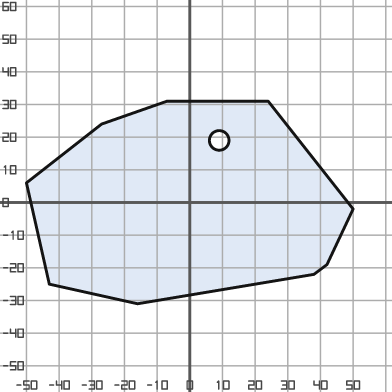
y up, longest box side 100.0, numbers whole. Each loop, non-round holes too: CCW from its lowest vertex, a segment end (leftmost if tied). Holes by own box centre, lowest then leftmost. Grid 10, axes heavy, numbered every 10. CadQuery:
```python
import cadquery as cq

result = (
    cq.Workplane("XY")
    .moveTo(-16.0, -31.0)
    .lineTo(38.0, -22.0)
    .lineTo(42.0, -19.0)
    .lineTo(50.0, -2.0)
    .lineTo(24.0, 31.0)
    .lineTo(-7.0, 31.0)
    .lineTo(-27.0, 24.0)
    .lineTo(-50.0, 6.0)
    .lineTo(-43.0, -25.0)
    .close()
    .moveTo(9.0, 19.0)
    .circle(3.0)
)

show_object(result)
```